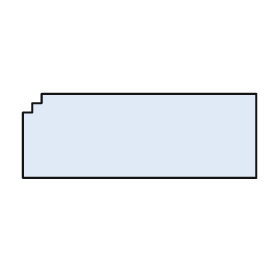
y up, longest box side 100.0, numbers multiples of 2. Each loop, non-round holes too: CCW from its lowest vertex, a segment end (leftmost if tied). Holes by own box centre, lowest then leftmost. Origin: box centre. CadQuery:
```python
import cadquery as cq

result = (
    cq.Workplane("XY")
    .moveTo(-50.0, -18.0)
    .lineTo(50.0, -18.0)
    .lineTo(50.0, 18.0)
    .lineTo(-42.0, 18.0)
    .lineTo(-42.0, 14.0)
    .lineTo(-46.0, 14.0)
    .lineTo(-46.0, 10.0)
    .lineTo(-50.0, 10.0)
    .close()
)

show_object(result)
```